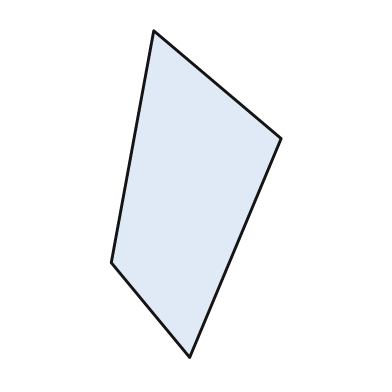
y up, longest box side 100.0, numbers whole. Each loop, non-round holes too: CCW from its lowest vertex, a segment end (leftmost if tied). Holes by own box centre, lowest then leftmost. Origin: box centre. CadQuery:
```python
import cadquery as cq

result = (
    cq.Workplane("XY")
    .moveTo(-2.0, -50.0)
    .lineTo(26.0, 17.0)
    .lineTo(-13.0, 50.0)
    .lineTo(-26.0, -21.0)
    .close()
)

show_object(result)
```